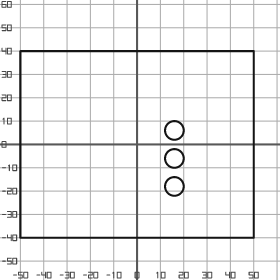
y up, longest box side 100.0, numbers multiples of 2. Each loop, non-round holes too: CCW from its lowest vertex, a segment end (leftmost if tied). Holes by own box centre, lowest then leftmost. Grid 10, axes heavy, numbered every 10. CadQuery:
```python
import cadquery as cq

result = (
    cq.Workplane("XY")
    .moveTo(-50.0, -40.0)
    .lineTo(50.0, -40.0)
    .lineTo(50.0, 40.0)
    .lineTo(-50.0, 40.0)
    .close()
    .moveTo(16.0, -18.0)
    .circle(4.0)
    .moveTo(16.0, -6.0)
    .circle(4.0)
    .moveTo(16.0, 6.0)
    .circle(4.0)
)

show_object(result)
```